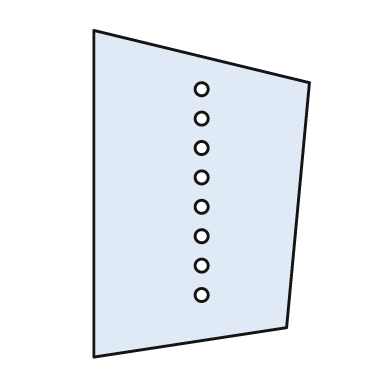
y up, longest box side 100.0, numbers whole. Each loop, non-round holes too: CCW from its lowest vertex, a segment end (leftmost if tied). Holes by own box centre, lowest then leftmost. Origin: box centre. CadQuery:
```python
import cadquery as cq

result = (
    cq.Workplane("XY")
    .moveTo(-33.0, -50.0)
    .lineTo(26.0, -41.0)
    .lineTo(33.0, 34.0)
    .lineTo(-33.0, 50.0)
    .close()
    .moveTo(0.0, -31.0)
    .circle(2.0)
    .moveTo(0.0, -22.0)
    .circle(2.0)
    .moveTo(0.0, -13.0)
    .circle(2.0)
    .moveTo(0.0, -4.0)
    .circle(2.0)
    .moveTo(0.0, 5.0)
    .circle(2.0)
    .moveTo(0.0, 14.0)
    .circle(2.0)
    .moveTo(0.0, 23.0)
    .circle(2.0)
    .moveTo(0.0, 32.0)
    .circle(2.0)
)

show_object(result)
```